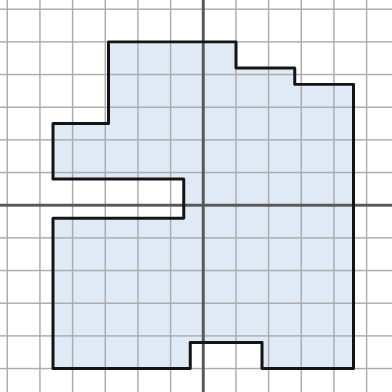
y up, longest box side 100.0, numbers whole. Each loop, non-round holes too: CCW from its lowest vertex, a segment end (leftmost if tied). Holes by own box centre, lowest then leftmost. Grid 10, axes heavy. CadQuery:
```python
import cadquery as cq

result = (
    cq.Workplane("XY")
    .moveTo(-46.0, -50.0)
    .lineTo(-4.0, -50.0)
    .lineTo(-4.0, -42.0)
    .lineTo(18.0, -42.0)
    .lineTo(18.0, -50.0)
    .lineTo(46.0, -50.0)
    .lineTo(46.0, 37.0)
    .lineTo(28.0, 37.0)
    .lineTo(28.0, 42.0)
    .lineTo(10.0, 42.0)
    .lineTo(10.0, 50.0)
    .lineTo(-29.0, 50.0)
    .lineTo(-29.0, 25.0)
    .lineTo(-46.0, 25.0)
    .lineTo(-46.0, 8.0)
    .lineTo(-6.0, 8.0)
    .lineTo(-6.0, -4.0)
    .lineTo(-46.0, -4.0)
    .close()
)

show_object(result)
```